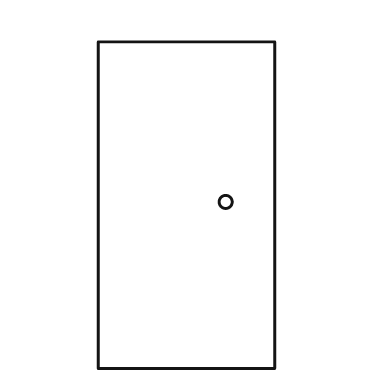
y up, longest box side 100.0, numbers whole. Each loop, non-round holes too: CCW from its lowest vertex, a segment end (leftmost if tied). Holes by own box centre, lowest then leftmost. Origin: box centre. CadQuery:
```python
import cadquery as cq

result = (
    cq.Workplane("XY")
    .moveTo(-27.0, -50.0)
    .lineTo(27.0, -50.0)
    .lineTo(27.0, 50.0)
    .lineTo(-27.0, 50.0)
    .close()
    .moveTo(12.0, 1.0)
    .circle(2.0)
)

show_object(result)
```